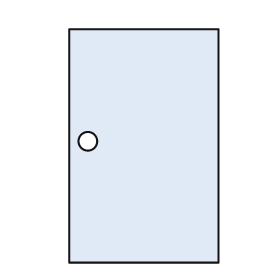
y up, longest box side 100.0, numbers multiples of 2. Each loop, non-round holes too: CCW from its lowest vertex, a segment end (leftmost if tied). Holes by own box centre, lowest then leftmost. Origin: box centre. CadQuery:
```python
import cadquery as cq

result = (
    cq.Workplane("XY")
    .moveTo(-32.0, -50.0)
    .lineTo(32.0, -50.0)
    .lineTo(32.0, 50.0)
    .lineTo(-32.0, 50.0)
    .close()
    .moveTo(-24.0, 2.0)
    .circle(4.0)
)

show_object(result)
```